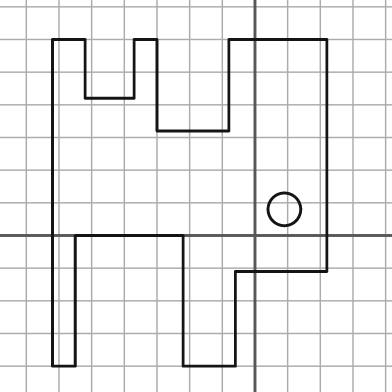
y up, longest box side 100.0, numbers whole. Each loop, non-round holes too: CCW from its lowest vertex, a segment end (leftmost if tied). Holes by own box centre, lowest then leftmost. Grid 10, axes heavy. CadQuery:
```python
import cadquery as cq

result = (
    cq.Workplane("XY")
    .moveTo(-62.0, -40.0)
    .lineTo(-55.0, -40.0)
    .lineTo(-55.0, 0.0)
    .lineTo(-22.0, 0.0)
    .lineTo(-22.0, -40.0)
    .lineTo(-6.0, -40.0)
    .lineTo(-6.0, -11.0)
    .lineTo(22.0, -11.0)
    .lineTo(22.0, 60.0)
    .lineTo(-8.0, 60.0)
    .lineTo(-8.0, 32.0)
    .lineTo(-30.0, 32.0)
    .lineTo(-30.0, 60.0)
    .lineTo(-37.0, 60.0)
    .lineTo(-37.0, 42.0)
    .lineTo(-52.0, 42.0)
    .lineTo(-52.0, 60.0)
    .lineTo(-62.0, 60.0)
    .close()
    .moveTo(9.0, 8.0)
    .circle(5.0)
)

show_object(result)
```